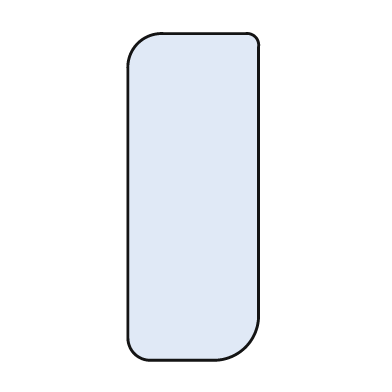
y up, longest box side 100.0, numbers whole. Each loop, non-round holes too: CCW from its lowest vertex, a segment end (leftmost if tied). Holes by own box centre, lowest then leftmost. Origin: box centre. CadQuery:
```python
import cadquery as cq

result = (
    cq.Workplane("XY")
    .moveTo(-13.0, -50.0)
    .lineTo(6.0, -50.0)
    .threePointArc((16.0, -46.0), (20.0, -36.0))
    .lineTo(20.0, 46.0)
    .threePointArc((19.0, 49.0), (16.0, 50.0))
    .lineTo(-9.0, 50.0)
    .threePointArc((-17.0, 47.0), (-20.0, 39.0))
    .lineTo(-20.0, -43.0)
    .threePointArc((-18.0, -48.0), (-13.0, -50.0))
    .close()
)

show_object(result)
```